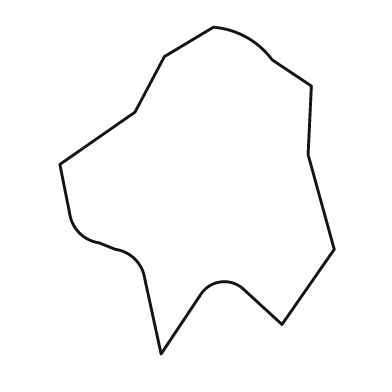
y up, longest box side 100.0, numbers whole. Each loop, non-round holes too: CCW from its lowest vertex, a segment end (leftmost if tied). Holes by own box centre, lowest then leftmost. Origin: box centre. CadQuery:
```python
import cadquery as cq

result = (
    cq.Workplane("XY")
    .moveTo(-11.0, -50.0)
    .lineTo(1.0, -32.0)
    .threePointArc((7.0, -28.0), (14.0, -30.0))
    .lineTo(26.0, -41.0)
    .lineTo(42.0, -18.0)
    .lineTo(34.0, 11.0)
    .lineTo(35.0, 32.0)
    .lineTo(23.0, 40.0)
    .threePointArc((15.0, 47.0), (5.0, 50.0))
    .lineTo(-10.0, 41.0)
    .lineTo(-19.0, 24.0)
    .lineTo(-42.0, 8.0)
    .lineTo(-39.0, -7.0)
    .threePointArc((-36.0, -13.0), (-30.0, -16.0))
    .lineTo(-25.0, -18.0)
    .threePointArc((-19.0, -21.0), (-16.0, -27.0))
    .close()
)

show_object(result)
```